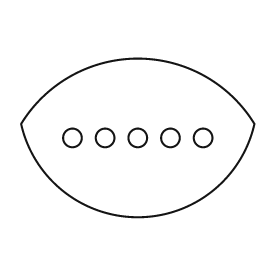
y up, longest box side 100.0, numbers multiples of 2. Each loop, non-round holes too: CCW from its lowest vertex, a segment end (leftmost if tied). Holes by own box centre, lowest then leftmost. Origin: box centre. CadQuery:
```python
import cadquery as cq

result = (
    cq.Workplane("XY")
    .moveTo(-50.0, 6.0)
    .threePointArc((0.0, -34.0), (50.0, 6.0))
    .threePointArc((0.0, 34.0), (-50.0, 6.0))
    .close()
    .moveTo(-28.0, 0.0)
    .circle(4.0)
    .moveTo(-14.0, 0.0)
    .circle(4.0)
    .moveTo(0.0, 0.0)
    .circle(4.0)
    .moveTo(14.0, 0.0)
    .circle(4.0)
    .moveTo(28.0, 0.0)
    .circle(4.0)
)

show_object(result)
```